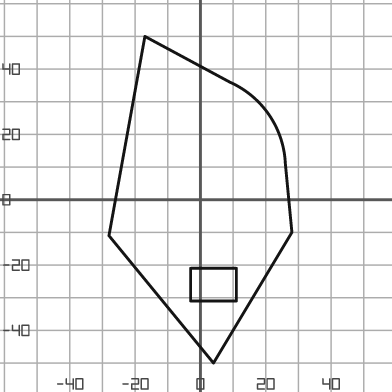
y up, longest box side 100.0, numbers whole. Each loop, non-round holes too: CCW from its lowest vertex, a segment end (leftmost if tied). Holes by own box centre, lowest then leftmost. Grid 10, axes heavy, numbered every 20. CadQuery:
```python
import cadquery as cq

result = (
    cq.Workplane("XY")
    .moveTo(4.0, -50.0)
    .lineTo(28.0, -10.0)
    .lineTo(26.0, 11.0)
    .threePointArc((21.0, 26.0), (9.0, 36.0))
    .lineTo(-17.0, 50.0)
    .lineTo(-28.0, -11.0)
    .close()
    .moveTo(-3.0, -31.0)
    .lineTo(11.0, -31.0)
    .lineTo(11.0, -21.0)
    .lineTo(-3.0, -21.0)
    .close()
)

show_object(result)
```